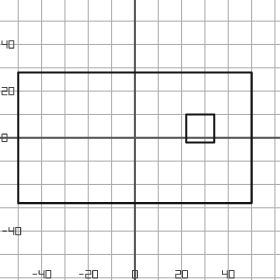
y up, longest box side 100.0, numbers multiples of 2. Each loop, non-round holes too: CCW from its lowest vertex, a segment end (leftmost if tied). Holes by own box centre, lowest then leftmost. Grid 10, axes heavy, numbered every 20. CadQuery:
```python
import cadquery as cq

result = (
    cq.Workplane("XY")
    .moveTo(-50.0, -28.0)
    .lineTo(50.0, -28.0)
    .lineTo(50.0, 28.0)
    .lineTo(-50.0, 28.0)
    .close()
    .moveTo(22.0, -2.0)
    .lineTo(34.0, -2.0)
    .lineTo(34.0, 10.0)
    .lineTo(22.0, 10.0)
    .close()
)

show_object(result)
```